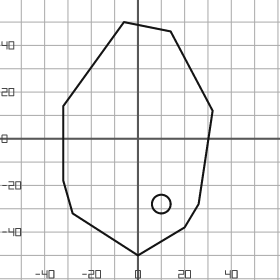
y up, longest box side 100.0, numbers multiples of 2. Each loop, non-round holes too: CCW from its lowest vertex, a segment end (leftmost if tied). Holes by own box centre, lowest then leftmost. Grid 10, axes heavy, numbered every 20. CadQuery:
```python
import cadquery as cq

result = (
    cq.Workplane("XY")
    .moveTo(0.0, -50.0)
    .lineTo(20.0, -38.0)
    .lineTo(26.0, -28.0)
    .lineTo(32.0, 12.0)
    .lineTo(14.0, 46.0)
    .lineTo(-6.0, 50.0)
    .lineTo(-32.0, 14.0)
    .lineTo(-32.0, -18.0)
    .lineTo(-28.0, -32.0)
    .close()
    .moveTo(10.0, -28.0)
    .circle(4.0)
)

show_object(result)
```